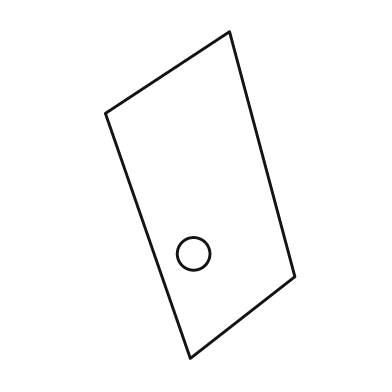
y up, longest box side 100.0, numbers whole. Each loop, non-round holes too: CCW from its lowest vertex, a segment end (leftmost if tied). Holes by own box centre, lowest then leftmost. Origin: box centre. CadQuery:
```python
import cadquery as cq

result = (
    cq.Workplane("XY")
    .moveTo(-3.0, -50.0)
    .lineTo(29.0, -25.0)
    .lineTo(9.0, 50.0)
    .lineTo(-29.0, 25.0)
    .close()
    .moveTo(-2.0, -18.0)
    .circle(5.0)
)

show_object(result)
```